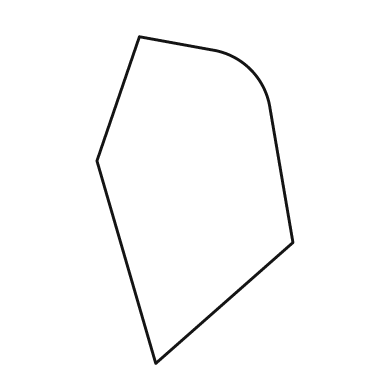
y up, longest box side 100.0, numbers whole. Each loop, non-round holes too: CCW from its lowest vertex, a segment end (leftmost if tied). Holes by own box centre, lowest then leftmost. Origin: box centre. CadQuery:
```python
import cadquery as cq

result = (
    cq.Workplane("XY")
    .moveTo(-12.0, -50.0)
    .lineTo(30.0, -13.0)
    .lineTo(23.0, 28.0)
    .threePointArc((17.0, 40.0), (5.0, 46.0))
    .lineTo(-17.0, 50.0)
    .lineTo(-30.0, 12.0)
    .close()
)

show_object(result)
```